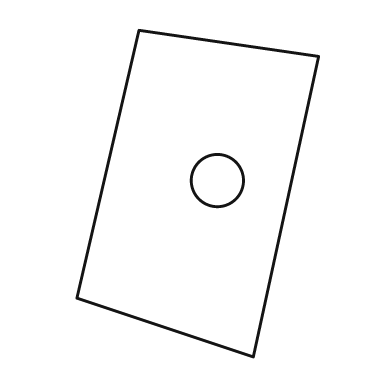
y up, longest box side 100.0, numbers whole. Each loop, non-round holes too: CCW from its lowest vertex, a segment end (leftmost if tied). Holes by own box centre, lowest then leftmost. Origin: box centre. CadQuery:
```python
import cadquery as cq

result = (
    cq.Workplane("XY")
    .moveTo(17.0, -50.0)
    .lineTo(37.0, 42.0)
    .lineTo(-18.0, 50.0)
    .lineTo(-37.0, -32.0)
    .close()
    .moveTo(6.0, 4.0)
    .circle(8.0)
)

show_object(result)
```